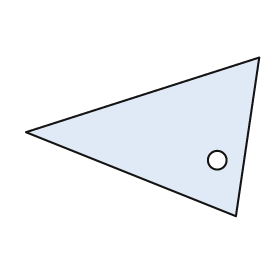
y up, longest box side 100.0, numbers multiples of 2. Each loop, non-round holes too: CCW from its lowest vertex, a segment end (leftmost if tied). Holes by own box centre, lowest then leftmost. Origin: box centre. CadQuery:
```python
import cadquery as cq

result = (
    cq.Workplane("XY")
    .moveTo(40.0, -34.0)
    .lineTo(50.0, 34.0)
    .lineTo(-50.0, 2.0)
    .close()
    .moveTo(32.0, -10.0)
    .circle(4.0)
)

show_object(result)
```